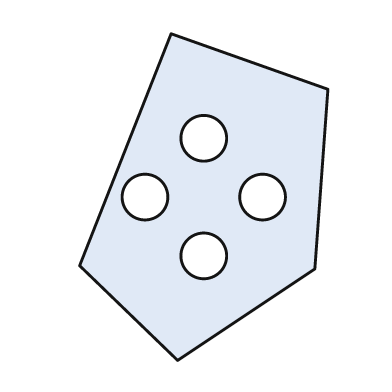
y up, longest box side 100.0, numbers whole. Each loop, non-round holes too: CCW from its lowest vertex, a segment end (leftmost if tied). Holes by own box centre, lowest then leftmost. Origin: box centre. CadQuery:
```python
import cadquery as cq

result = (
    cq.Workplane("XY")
    .moveTo(-8.0, -50.0)
    .lineTo(34.0, -22.0)
    .lineTo(38.0, 33.0)
    .lineTo(-10.0, 50.0)
    .lineTo(-38.0, -21.0)
    .close()
    .moveTo(0.0, -18.0)
    .circle(7.0)
    .moveTo(-18.0, 0.0)
    .circle(7.0)
    .moveTo(18.0, 0.0)
    .circle(7.0)
    .moveTo(0.0, 18.0)
    .circle(7.0)
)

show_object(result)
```